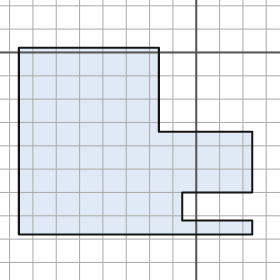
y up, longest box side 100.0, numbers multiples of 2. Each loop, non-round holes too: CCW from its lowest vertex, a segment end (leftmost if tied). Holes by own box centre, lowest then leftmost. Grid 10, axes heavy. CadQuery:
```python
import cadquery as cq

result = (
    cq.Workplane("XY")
    .moveTo(-76.0, -78.0)
    .lineTo(24.0, -78.0)
    .lineTo(24.0, -72.0)
    .lineTo(-6.0, -72.0)
    .lineTo(-6.0, -60.0)
    .lineTo(24.0, -60.0)
    .lineTo(24.0, -34.0)
    .lineTo(-16.0, -34.0)
    .lineTo(-16.0, 2.0)
    .lineTo(-76.0, 2.0)
    .close()
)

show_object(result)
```